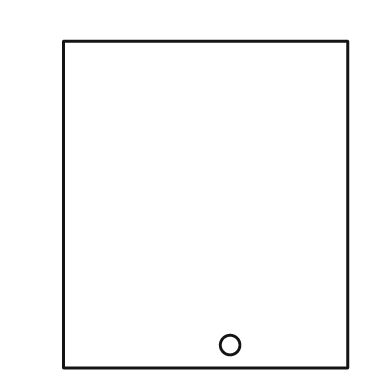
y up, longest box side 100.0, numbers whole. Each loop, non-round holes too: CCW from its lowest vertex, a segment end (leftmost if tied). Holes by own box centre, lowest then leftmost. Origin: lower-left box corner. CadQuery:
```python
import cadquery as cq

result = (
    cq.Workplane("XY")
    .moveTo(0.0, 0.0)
    .lineTo(87.0, 0.0)
    .lineTo(87.0, 100.0)
    .lineTo(0.0, 100.0)
    .close()
    .moveTo(51.0, 7.0)
    .circle(3.0)
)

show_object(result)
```